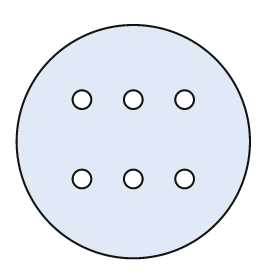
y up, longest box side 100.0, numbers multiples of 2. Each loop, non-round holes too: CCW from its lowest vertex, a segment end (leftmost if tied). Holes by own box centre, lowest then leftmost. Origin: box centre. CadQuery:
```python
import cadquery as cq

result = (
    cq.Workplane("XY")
    .moveTo(0.0, 0.0)
    .circle(50.0)
    .moveTo(-22.0, -16.0)
    .circle(4.0)
    .moveTo(0.0, -16.0)
    .circle(4.0)
    .moveTo(22.0, -16.0)
    .circle(4.0)
    .moveTo(-22.0, 18.0)
    .circle(4.0)
    .moveTo(0.0, 18.0)
    .circle(4.0)
    .moveTo(22.0, 18.0)
    .circle(4.0)
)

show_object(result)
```